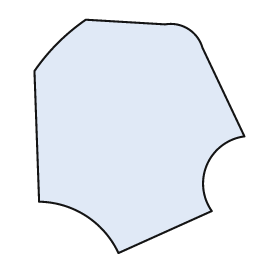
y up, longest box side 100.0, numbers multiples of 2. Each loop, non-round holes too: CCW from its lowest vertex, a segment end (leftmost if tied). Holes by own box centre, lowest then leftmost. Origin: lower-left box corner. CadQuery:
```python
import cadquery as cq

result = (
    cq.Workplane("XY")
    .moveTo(36.0, 0.0)
    .lineTo(76.0, 18.0)
    .threePointArc((74.0, 38.0), (90.0, 50.0))
    .lineTo(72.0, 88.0)
    .threePointArc((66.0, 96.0), (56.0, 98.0))
    .lineTo(22.0, 100.0)
    .threePointArc((10.0, 90.0), (0.0, 78.0))
    .lineTo(2.0, 22.0)
    .threePointArc((22.0, 16.0), (36.0, 0.0))
    .close()
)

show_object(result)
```